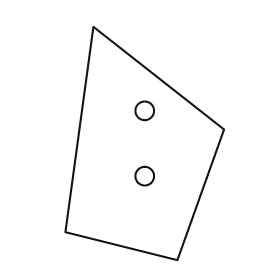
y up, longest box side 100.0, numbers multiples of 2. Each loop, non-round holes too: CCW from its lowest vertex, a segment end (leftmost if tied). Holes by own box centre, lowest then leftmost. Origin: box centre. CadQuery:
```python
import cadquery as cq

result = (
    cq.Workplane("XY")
    .moveTo(14.0, -50.0)
    .lineTo(34.0, 6.0)
    .lineTo(-22.0, 50.0)
    .lineTo(-34.0, -38.0)
    .close()
    .moveTo(0.0, -14.0)
    .circle(4.0)
    .moveTo(0.0, 14.0)
    .circle(4.0)
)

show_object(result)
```